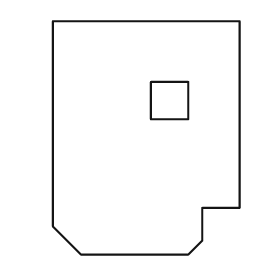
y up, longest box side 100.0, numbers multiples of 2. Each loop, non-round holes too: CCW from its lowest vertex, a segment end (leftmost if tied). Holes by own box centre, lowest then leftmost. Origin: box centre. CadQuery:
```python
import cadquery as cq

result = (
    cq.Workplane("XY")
    .moveTo(-28.0, -50.0)
    .lineTo(18.0, -50.0)
    .lineTo(24.0, -44.0)
    .lineTo(24.0, -30.0)
    .lineTo(40.0, -30.0)
    .lineTo(40.0, 50.0)
    .lineTo(-40.0, 50.0)
    .lineTo(-40.0, -38.0)
    .close()
    .moveTo(2.0, 8.0)
    .lineTo(18.0, 8.0)
    .lineTo(18.0, 24.0)
    .lineTo(2.0, 24.0)
    .close()
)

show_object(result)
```